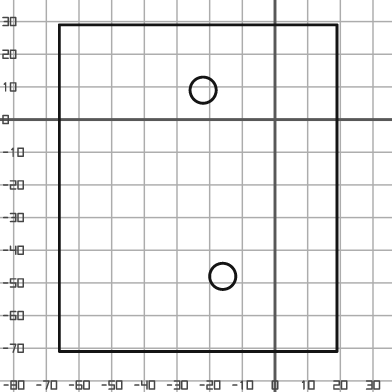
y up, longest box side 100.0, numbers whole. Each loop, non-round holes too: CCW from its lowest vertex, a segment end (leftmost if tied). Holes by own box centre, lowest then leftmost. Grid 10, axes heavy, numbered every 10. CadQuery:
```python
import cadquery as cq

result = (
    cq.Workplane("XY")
    .moveTo(-66.0, -71.0)
    .lineTo(19.0, -71.0)
    .lineTo(19.0, 29.0)
    .lineTo(-66.0, 29.0)
    .close()
    .moveTo(-16.0, -48.0)
    .circle(4.0)
    .moveTo(-22.0, 9.0)
    .circle(4.0)
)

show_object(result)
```